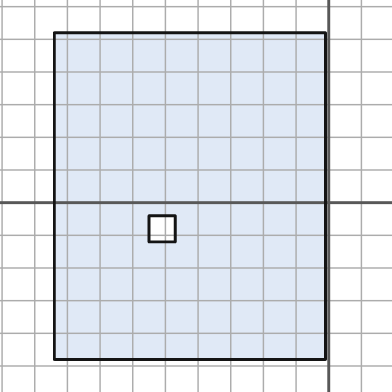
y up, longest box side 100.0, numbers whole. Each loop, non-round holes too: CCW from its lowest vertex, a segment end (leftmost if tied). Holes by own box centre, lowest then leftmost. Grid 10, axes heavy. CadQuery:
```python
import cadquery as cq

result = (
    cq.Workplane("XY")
    .moveTo(-84.0, -48.0)
    .lineTo(-1.0, -48.0)
    .lineTo(-1.0, 52.0)
    .lineTo(-84.0, 52.0)
    .close()
    .moveTo(-55.0, -12.0)
    .lineTo(-47.0, -12.0)
    .lineTo(-47.0, -4.0)
    .lineTo(-55.0, -4.0)
    .close()
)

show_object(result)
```